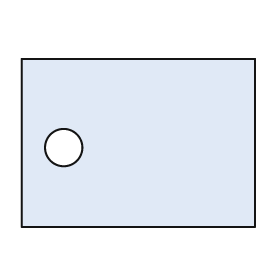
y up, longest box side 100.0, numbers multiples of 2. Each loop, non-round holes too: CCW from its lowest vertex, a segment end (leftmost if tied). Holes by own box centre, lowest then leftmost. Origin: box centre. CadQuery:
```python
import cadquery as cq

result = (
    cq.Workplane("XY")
    .moveTo(-50.0, -36.0)
    .lineTo(50.0, -36.0)
    .lineTo(50.0, 36.0)
    .lineTo(-50.0, 36.0)
    .close()
    .moveTo(-32.0, -2.0)
    .circle(8.0)
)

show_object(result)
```